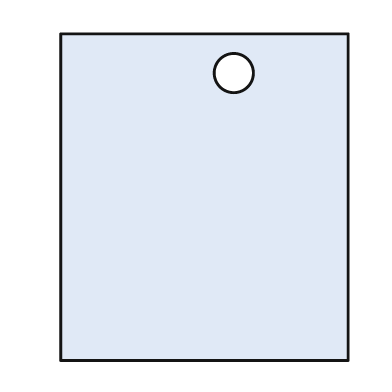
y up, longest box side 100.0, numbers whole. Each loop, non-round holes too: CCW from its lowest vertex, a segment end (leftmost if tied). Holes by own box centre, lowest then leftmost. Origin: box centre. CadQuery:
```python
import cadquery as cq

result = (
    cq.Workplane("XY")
    .moveTo(-44.0, -50.0)
    .lineTo(44.0, -50.0)
    .lineTo(44.0, 50.0)
    .lineTo(-44.0, 50.0)
    .close()
    .moveTo(9.0, 38.0)
    .circle(6.0)
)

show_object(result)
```